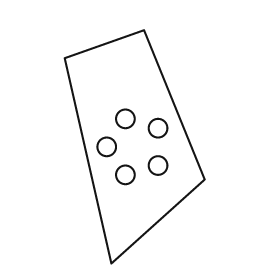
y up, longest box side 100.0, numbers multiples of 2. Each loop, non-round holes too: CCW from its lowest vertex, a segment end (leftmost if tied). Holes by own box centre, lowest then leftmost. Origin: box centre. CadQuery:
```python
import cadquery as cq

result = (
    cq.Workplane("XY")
    .moveTo(-10.0, -50.0)
    .lineTo(30.0, -14.0)
    .lineTo(4.0, 50.0)
    .lineTo(-30.0, 38.0)
    .close()
    .moveTo(-4.0, -12.0)
    .circle(4.0)
    .moveTo(10.0, -8.0)
    .circle(4.0)
    .moveTo(-12.0, 0.0)
    .circle(4.0)
    .moveTo(10.0, 8.0)
    .circle(4.0)
    .moveTo(-4.0, 12.0)
    .circle(4.0)
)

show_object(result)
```